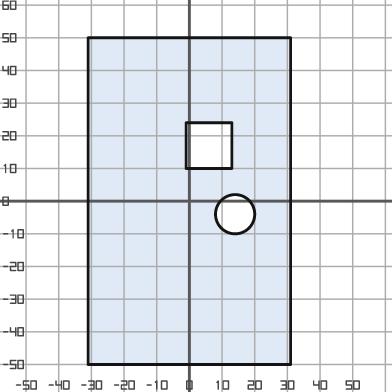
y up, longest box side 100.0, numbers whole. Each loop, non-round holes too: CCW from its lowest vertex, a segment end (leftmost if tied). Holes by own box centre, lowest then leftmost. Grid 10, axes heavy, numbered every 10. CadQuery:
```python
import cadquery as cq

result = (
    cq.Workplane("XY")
    .moveTo(-31.0, -50.0)
    .lineTo(31.0, -50.0)
    .lineTo(31.0, 50.0)
    .lineTo(-31.0, 50.0)
    .close()
    .moveTo(14.0, -4.0)
    .circle(6.0)
    .moveTo(-1.0, 10.0)
    .lineTo(13.0, 10.0)
    .lineTo(13.0, 24.0)
    .lineTo(-1.0, 24.0)
    .close()
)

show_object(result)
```